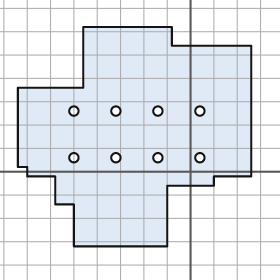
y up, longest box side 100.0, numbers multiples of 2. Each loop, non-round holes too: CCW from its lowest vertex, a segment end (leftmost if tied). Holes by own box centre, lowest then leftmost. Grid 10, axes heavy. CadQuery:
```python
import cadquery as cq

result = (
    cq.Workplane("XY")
    .moveTo(-50.0, -32.0)
    .lineTo(-10.0, -32.0)
    .lineTo(-10.0, -6.0)
    .lineTo(10.0, -6.0)
    .lineTo(10.0, -2.0)
    .lineTo(26.0, -2.0)
    .lineTo(26.0, 54.0)
    .lineTo(-8.0, 54.0)
    .lineTo(-8.0, 62.0)
    .lineTo(-46.0, 62.0)
    .lineTo(-46.0, 36.0)
    .lineTo(-74.0, 36.0)
    .lineTo(-74.0, 2.0)
    .lineTo(-70.0, 2.0)
    .lineTo(-70.0, -2.0)
    .lineTo(-58.0, -2.0)
    .lineTo(-58.0, -14.0)
    .lineTo(-50.0, -14.0)
    .close()
    .moveTo(-50.0, 6.0)
    .circle(2.0)
    .moveTo(-32.0, 6.0)
    .circle(2.0)
    .moveTo(-14.0, 6.0)
    .circle(2.0)
    .moveTo(4.0, 6.0)
    .circle(2.0)
    .moveTo(-50.0, 26.0)
    .circle(2.0)
    .moveTo(-32.0, 26.0)
    .circle(2.0)
    .moveTo(-14.0, 26.0)
    .circle(2.0)
    .moveTo(4.0, 26.0)
    .circle(2.0)
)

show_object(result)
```